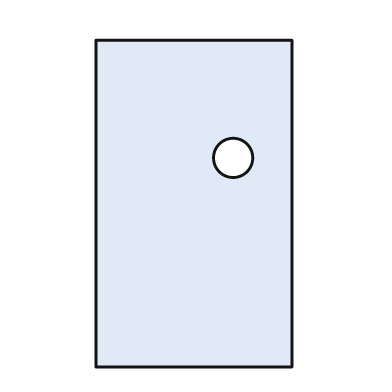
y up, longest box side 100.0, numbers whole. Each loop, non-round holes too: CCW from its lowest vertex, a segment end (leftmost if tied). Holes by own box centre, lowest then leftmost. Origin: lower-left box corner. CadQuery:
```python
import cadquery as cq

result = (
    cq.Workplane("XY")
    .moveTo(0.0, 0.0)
    .lineTo(60.0, 0.0)
    .lineTo(60.0, 100.0)
    .lineTo(0.0, 100.0)
    .close()
    .moveTo(42.0, 64.0)
    .circle(6.0)
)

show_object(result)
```